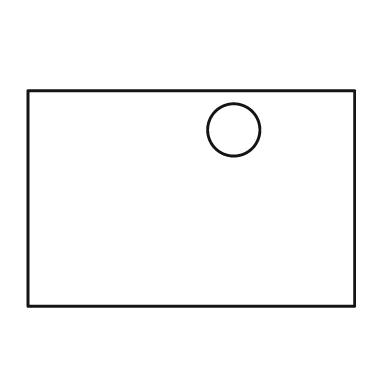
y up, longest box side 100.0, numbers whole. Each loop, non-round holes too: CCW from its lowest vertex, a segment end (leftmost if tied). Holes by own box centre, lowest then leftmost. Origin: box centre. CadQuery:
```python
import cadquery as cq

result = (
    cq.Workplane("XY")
    .moveTo(-50.0, -33.0)
    .lineTo(50.0, -33.0)
    .lineTo(50.0, 33.0)
    .lineTo(-50.0, 33.0)
    .close()
    .moveTo(13.0, 21.0)
    .circle(8.0)
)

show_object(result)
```